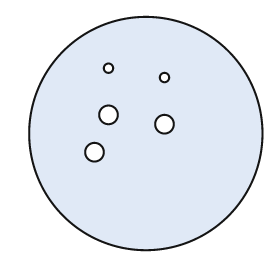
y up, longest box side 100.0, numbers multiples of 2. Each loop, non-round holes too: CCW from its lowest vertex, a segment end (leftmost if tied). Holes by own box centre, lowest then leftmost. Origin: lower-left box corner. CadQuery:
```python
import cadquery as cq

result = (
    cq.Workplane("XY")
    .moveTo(50.0, 50.0)
    .circle(50.0)
    .moveTo(28.0, 42.0)
    .circle(4.0)
    .moveTo(58.0, 54.0)
    .circle(4.0)
    .moveTo(34.0, 58.0)
    .circle(4.0)
    .moveTo(58.0, 74.0)
    .circle(2.0)
    .moveTo(34.0, 78.0)
    .circle(2.0)
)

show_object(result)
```